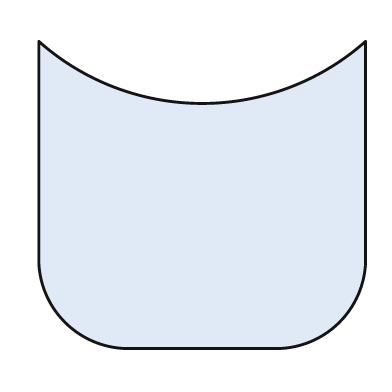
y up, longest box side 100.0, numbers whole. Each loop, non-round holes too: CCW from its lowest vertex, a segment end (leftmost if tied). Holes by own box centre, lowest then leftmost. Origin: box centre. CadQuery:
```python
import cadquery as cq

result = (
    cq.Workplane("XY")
    .moveTo(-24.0, -47.0)
    .lineTo(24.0, -47.0)
    .threePointArc((42.0, -39.0), (50.0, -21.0))
    .lineTo(50.0, 47.0)
    .threePointArc((0.0, 28.0), (-50.0, 47.0))
    .lineTo(-50.0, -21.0)
    .threePointArc((-42.0, -39.0), (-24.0, -47.0))
    .close()
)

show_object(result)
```